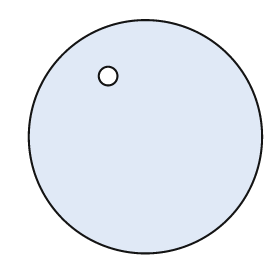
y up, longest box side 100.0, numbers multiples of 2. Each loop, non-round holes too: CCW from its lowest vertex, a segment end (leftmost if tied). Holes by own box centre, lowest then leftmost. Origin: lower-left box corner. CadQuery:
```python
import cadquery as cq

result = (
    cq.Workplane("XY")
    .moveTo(50.0, 50.0)
    .circle(50.0)
    .moveTo(34.0, 76.0)
    .circle(4.0)
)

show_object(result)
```